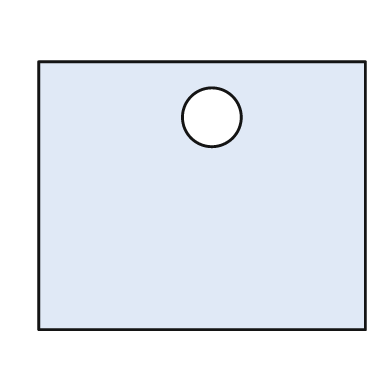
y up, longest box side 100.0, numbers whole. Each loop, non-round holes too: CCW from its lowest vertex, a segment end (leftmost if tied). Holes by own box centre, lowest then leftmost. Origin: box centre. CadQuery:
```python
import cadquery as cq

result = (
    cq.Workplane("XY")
    .moveTo(-50.0, -41.0)
    .lineTo(50.0, -41.0)
    .lineTo(50.0, 41.0)
    .lineTo(-50.0, 41.0)
    .close()
    .moveTo(3.0, 24.0)
    .circle(9.0)
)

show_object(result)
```